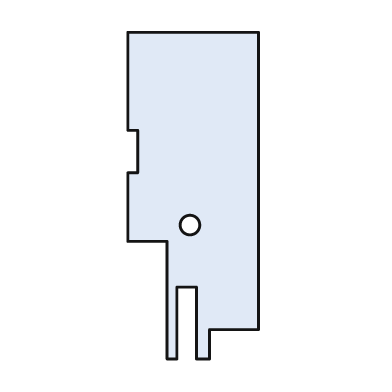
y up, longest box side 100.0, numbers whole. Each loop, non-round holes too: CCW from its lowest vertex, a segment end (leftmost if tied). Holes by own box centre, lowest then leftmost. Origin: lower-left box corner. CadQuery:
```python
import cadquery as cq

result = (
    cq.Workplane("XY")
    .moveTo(12.0, 0.0)
    .lineTo(15.0, 0.0)
    .lineTo(15.0, 22.0)
    .lineTo(21.0, 22.0)
    .lineTo(21.0, 0.0)
    .lineTo(25.0, 0.0)
    .lineTo(25.0, 9.0)
    .lineTo(40.0, 9.0)
    .lineTo(40.0, 100.0)
    .lineTo(0.0, 100.0)
    .lineTo(0.0, 70.0)
    .lineTo(3.0, 70.0)
    .lineTo(3.0, 57.0)
    .lineTo(0.0, 57.0)
    .lineTo(0.0, 36.0)
    .lineTo(12.0, 36.0)
    .close()
    .moveTo(19.0, 41.0)
    .circle(3.0)
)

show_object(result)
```